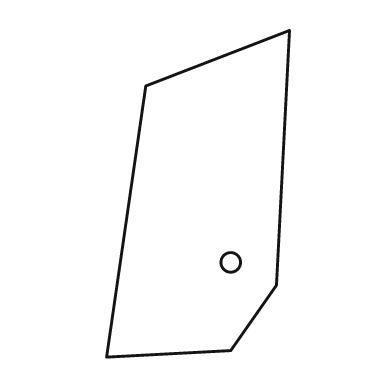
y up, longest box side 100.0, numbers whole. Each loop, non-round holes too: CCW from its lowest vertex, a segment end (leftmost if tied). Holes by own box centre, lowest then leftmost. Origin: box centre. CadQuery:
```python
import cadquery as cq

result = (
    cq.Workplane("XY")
    .moveTo(-28.0, -50.0)
    .lineTo(10.0, -48.0)
    .lineTo(24.0, -28.0)
    .lineTo(28.0, 50.0)
    .lineTo(-16.0, 33.0)
    .close()
    .moveTo(10.0, -21.0)
    .circle(3.0)
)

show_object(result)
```